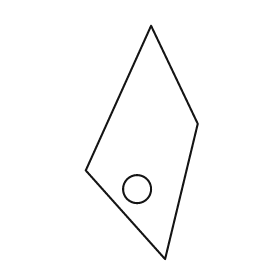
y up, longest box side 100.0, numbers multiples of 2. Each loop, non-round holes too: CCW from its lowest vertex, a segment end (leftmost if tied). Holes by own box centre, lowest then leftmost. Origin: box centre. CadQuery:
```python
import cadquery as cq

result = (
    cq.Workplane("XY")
    .moveTo(10.0, -50.0)
    .lineTo(24.0, 8.0)
    .lineTo(4.0, 50.0)
    .lineTo(-24.0, -12.0)
    .close()
    .moveTo(-2.0, -20.0)
    .circle(6.0)
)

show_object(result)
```